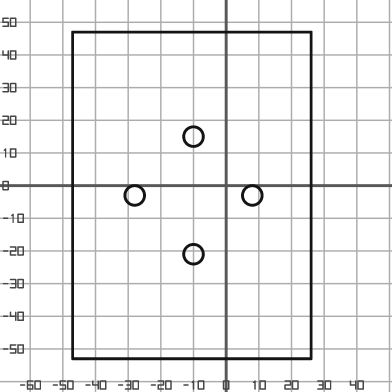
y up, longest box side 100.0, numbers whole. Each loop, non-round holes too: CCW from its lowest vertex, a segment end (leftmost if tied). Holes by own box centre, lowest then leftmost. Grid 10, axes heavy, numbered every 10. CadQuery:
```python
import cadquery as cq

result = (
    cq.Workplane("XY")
    .moveTo(-47.0, -53.0)
    .lineTo(26.0, -53.0)
    .lineTo(26.0, 47.0)
    .lineTo(-47.0, 47.0)
    .close()
    .moveTo(-10.0, -21.0)
    .circle(3.0)
    .moveTo(-28.0, -3.0)
    .circle(3.0)
    .moveTo(8.0, -3.0)
    .circle(3.0)
    .moveTo(-10.0, 15.0)
    .circle(3.0)
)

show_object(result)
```